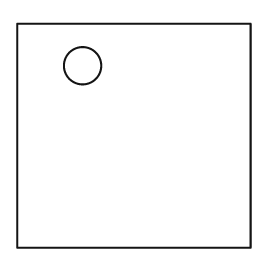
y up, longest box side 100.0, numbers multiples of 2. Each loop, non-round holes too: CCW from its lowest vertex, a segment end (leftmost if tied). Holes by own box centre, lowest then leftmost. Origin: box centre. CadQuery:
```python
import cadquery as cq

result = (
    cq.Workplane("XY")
    .moveTo(-50.0, -48.0)
    .lineTo(50.0, -48.0)
    .lineTo(50.0, 48.0)
    .lineTo(-50.0, 48.0)
    .close()
    .moveTo(-22.0, 30.0)
    .circle(8.0)
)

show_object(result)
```